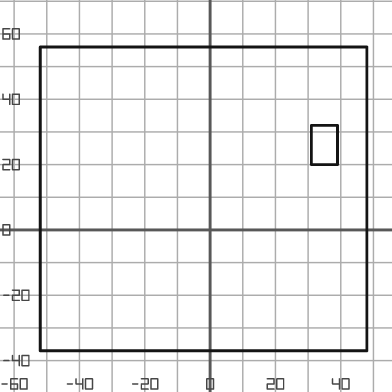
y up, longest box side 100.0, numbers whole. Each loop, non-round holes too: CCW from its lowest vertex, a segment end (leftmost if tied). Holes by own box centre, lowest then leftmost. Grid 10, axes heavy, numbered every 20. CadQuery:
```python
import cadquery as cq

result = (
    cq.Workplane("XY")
    .moveTo(-52.0, -37.0)
    .lineTo(48.0, -37.0)
    .lineTo(48.0, 56.0)
    .lineTo(-52.0, 56.0)
    .close()
    .moveTo(31.0, 20.0)
    .lineTo(39.0, 20.0)
    .lineTo(39.0, 32.0)
    .lineTo(31.0, 32.0)
    .close()
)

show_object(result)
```